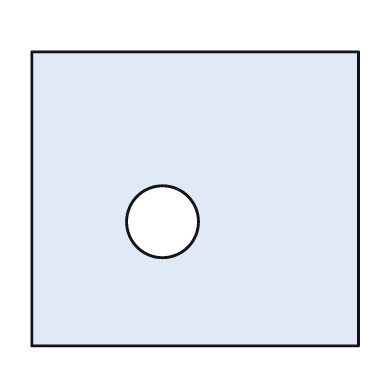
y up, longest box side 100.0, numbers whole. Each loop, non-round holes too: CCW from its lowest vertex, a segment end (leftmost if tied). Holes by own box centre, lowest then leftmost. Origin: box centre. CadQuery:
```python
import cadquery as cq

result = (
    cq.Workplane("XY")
    .moveTo(-50.0, -45.0)
    .lineTo(50.0, -45.0)
    .lineTo(50.0, 45.0)
    .lineTo(-50.0, 45.0)
    .close()
    .moveTo(-10.0, -7.0)
    .circle(11.0)
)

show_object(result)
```